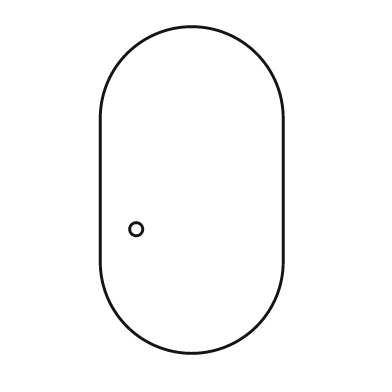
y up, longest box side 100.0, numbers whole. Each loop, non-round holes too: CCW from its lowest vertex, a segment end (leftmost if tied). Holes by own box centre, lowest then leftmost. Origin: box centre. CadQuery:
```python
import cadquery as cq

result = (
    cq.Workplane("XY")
    .moveTo(-28.0, -22.0)
    .threePointArc((0.0, -50.0), (28.0, -22.0))
    .lineTo(28.0, 22.0)
    .threePointArc((0.0, 50.0), (-28.0, 22.0))
    .close()
    .moveTo(-17.0, -12.0)
    .circle(2.0)
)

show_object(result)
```